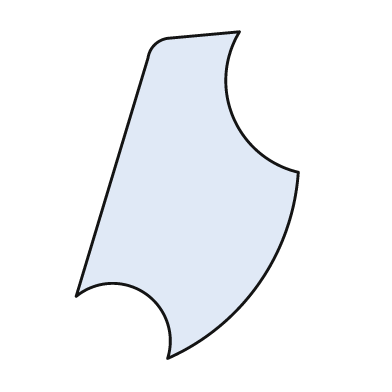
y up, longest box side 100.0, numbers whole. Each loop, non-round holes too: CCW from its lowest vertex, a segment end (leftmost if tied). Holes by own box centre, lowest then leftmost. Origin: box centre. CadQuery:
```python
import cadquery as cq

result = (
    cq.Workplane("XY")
    .moveTo(-6.0, -50.0)
    .threePointArc((22.0, -27.0), (34.0, 7.0))
    .threePointArc((14.0, 24.0), (16.0, 50.0))
    .lineTo(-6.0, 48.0)
    .threePointArc((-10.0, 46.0), (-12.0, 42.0))
    .lineTo(-34.0, -31.0)
    .threePointArc((-13.0, -30.0), (-6.0, -50.0))
    .close()
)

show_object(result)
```